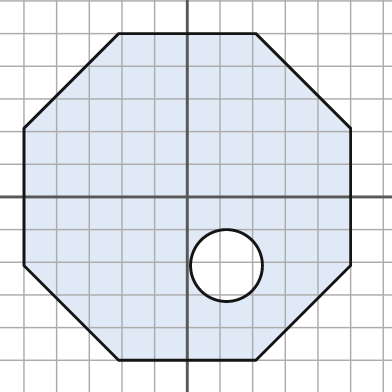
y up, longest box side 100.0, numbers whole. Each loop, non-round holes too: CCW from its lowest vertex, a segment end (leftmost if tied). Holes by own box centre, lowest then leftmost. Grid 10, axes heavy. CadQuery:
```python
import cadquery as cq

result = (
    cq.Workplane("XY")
    .moveTo(-21.0, -50.0)
    .lineTo(21.0, -50.0)
    .lineTo(50.0, -21.0)
    .lineTo(50.0, 21.0)
    .lineTo(21.0, 50.0)
    .lineTo(-21.0, 50.0)
    .lineTo(-50.0, 21.0)
    .lineTo(-50.0, -21.0)
    .close()
    .moveTo(12.0, -21.0)
    .circle(11.0)
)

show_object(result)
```